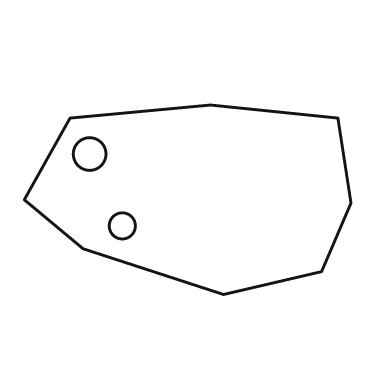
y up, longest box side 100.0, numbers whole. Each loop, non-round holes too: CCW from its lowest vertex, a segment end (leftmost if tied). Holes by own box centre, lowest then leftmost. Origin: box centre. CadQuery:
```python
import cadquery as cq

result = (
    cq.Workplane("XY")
    .moveTo(11.0, -29.0)
    .lineTo(41.0, -22.0)
    .lineTo(50.0, -1.0)
    .lineTo(46.0, 25.0)
    .lineTo(7.0, 29.0)
    .lineTo(-36.0, 25.0)
    .lineTo(-50.0, 0.0)
    .lineTo(-32.0, -15.0)
    .close()
    .moveTo(-20.0, -8.0)
    .circle(4.0)
    .moveTo(-30.0, 14.0)
    .circle(5.0)
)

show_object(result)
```